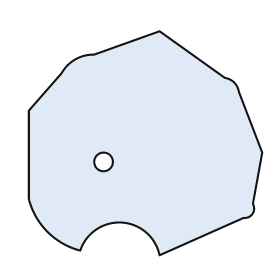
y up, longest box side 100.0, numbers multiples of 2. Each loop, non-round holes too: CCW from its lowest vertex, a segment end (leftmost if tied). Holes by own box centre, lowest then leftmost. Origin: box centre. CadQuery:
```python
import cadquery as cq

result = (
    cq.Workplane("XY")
    .moveTo(6.0, -48.0)
    .lineTo(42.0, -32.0)
    .threePointArc((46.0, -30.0), (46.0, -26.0))
    .lineTo(50.0, -4.0)
    .lineTo(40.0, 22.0)
    .threePointArc((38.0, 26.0), (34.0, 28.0))
    .lineTo(6.0, 48.0)
    .lineTo(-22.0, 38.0)
    .threePointArc((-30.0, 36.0), (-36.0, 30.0))
    .lineTo(-50.0, 14.0)
    .lineTo(-50.0, -24.0)
    .threePointArc((-42.0, -38.0), (-28.0, -46.0))
    .threePointArc((-10.0, -34.0), (6.0, -48.0))
    .close()
    .moveTo(-18.0, -8.0)
    .circle(4.0)
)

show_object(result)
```